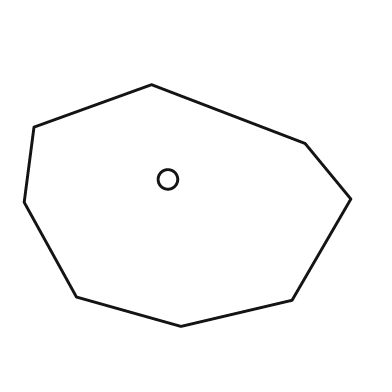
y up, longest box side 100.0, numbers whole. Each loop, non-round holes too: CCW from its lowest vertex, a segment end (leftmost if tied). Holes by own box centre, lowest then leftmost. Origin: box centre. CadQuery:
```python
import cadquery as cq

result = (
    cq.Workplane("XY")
    .moveTo(-2.0, -37.0)
    .lineTo(32.0, -29.0)
    .lineTo(50.0, 2.0)
    .lineTo(36.0, 19.0)
    .lineTo(-11.0, 37.0)
    .lineTo(-47.0, 24.0)
    .lineTo(-50.0, 1.0)
    .lineTo(-34.0, -28.0)
    .close()
    .moveTo(-6.0, 8.0)
    .circle(3.0)
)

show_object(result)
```